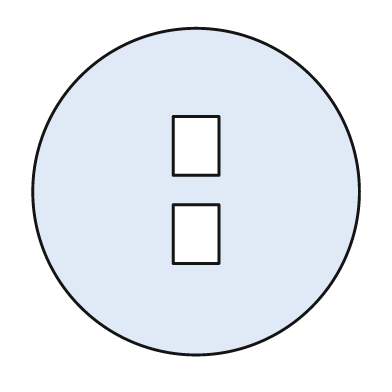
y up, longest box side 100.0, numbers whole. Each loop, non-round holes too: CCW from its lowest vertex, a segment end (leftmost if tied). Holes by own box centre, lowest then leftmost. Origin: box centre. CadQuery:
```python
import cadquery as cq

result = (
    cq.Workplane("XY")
    .moveTo(0.0, 0.0)
    .circle(50.0)
    .moveTo(-7.0, -22.0)
    .lineTo(7.0, -22.0)
    .lineTo(7.0, -4.0)
    .lineTo(-7.0, -4.0)
    .close()
    .moveTo(-7.0, 5.0)
    .lineTo(7.0, 5.0)
    .lineTo(7.0, 23.0)
    .lineTo(-7.0, 23.0)
    .close()
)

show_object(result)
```